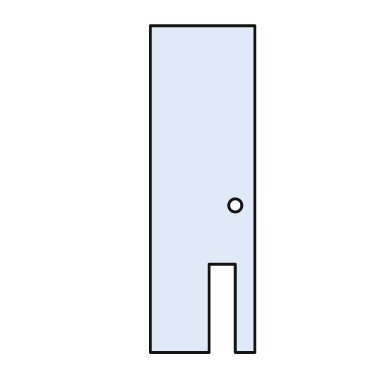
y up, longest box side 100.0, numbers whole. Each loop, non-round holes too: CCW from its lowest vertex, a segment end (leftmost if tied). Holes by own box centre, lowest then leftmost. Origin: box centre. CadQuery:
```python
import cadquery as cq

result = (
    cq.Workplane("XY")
    .moveTo(-16.0, -50.0)
    .lineTo(2.0, -50.0)
    .lineTo(2.0, -23.0)
    .lineTo(10.0, -23.0)
    .lineTo(10.0, -50.0)
    .lineTo(16.0, -50.0)
    .lineTo(16.0, 50.0)
    .lineTo(-16.0, 50.0)
    .close()
    .moveTo(10.0, -5.0)
    .circle(2.0)
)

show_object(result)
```